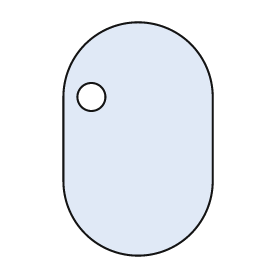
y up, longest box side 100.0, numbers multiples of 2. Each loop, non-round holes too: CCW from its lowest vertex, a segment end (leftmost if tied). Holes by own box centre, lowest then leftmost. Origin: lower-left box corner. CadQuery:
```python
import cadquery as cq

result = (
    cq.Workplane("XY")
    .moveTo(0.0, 32.0)
    .threePointArc((32.0, 0.0), (64.0, 32.0))
    .lineTo(64.0, 68.0)
    .threePointArc((32.0, 100.0), (0.0, 68.0))
    .close()
    .moveTo(12.0, 68.0)
    .circle(6.0)
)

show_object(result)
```